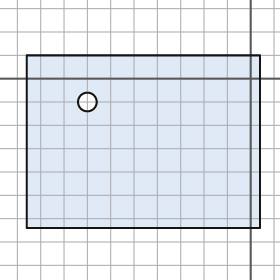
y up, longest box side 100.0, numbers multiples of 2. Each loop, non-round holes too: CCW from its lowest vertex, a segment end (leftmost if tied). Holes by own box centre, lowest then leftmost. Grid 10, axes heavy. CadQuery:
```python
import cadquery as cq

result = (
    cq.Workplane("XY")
    .moveTo(-96.0, -64.0)
    .lineTo(4.0, -64.0)
    .lineTo(4.0, 10.0)
    .lineTo(-96.0, 10.0)
    .close()
    .moveTo(-70.0, -10.0)
    .circle(4.0)
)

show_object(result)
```